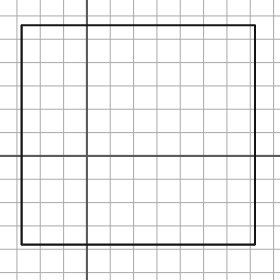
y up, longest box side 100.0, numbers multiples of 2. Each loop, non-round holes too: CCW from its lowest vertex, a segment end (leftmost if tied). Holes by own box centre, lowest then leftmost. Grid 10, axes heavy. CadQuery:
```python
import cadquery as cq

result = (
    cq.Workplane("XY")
    .moveTo(-28.0, -38.0)
    .lineTo(72.0, -38.0)
    .lineTo(72.0, 56.0)
    .lineTo(-28.0, 56.0)
    .close()
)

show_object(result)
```